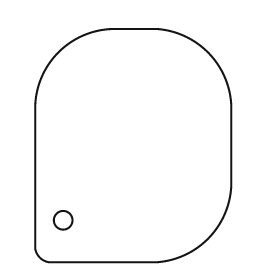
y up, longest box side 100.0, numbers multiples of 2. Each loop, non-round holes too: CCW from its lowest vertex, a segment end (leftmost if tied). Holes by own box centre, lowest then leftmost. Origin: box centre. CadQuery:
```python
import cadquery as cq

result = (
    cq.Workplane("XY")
    .moveTo(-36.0, -50.0)
    .lineTo(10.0, -50.0)
    .threePointArc((32.0, -40.0), (42.0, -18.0))
    .lineTo(42.0, 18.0)
    .threePointArc((32.0, 40.0), (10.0, 50.0))
    .lineTo(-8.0, 50.0)
    .threePointArc((-32.0, 40.0), (-42.0, 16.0))
    .lineTo(-42.0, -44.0)
    .threePointArc((-40.0, -48.0), (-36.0, -50.0))
    .close()
    .moveTo(-30.0, -32.0)
    .circle(4.0)
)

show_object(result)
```